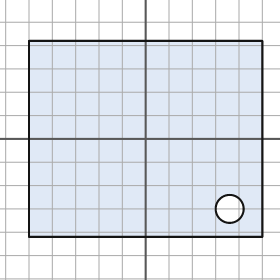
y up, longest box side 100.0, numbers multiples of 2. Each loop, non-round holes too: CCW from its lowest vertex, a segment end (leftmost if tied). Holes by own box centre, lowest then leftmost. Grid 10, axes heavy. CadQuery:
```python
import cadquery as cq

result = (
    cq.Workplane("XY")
    .moveTo(-50.0, -42.0)
    .lineTo(50.0, -42.0)
    .lineTo(50.0, 42.0)
    .lineTo(-50.0, 42.0)
    .close()
    .moveTo(36.0, -30.0)
    .circle(6.0)
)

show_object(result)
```